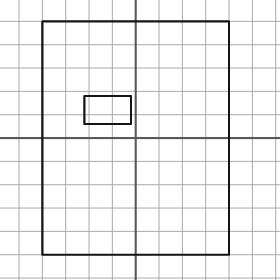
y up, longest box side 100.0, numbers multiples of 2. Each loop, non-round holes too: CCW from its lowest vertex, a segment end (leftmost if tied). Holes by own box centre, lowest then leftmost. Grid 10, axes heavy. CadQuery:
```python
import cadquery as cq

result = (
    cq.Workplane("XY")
    .moveTo(-40.0, -50.0)
    .lineTo(40.0, -50.0)
    .lineTo(40.0, 50.0)
    .lineTo(-40.0, 50.0)
    .close()
    .moveTo(-22.0, 6.0)
    .lineTo(-2.0, 6.0)
    .lineTo(-2.0, 18.0)
    .lineTo(-22.0, 18.0)
    .close()
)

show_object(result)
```